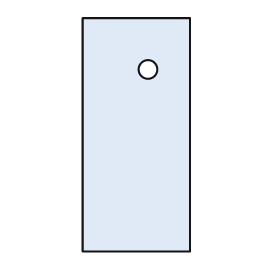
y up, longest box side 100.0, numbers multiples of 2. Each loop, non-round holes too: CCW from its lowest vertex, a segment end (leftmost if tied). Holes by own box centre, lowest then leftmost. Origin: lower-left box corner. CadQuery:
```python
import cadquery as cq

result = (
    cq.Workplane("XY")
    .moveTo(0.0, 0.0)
    .lineTo(46.0, 0.0)
    .lineTo(46.0, 100.0)
    .lineTo(0.0, 100.0)
    .close()
    .moveTo(28.0, 78.0)
    .circle(4.0)
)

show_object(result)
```